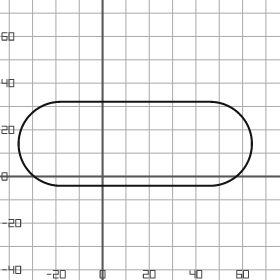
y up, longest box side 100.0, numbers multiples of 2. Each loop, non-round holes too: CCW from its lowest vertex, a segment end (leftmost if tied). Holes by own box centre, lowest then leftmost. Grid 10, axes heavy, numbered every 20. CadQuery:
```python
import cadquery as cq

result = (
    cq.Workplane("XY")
    .moveTo(-18.0, -4.0)
    .lineTo(46.0, -4.0)
    .threePointArc((64.0, 14.0), (46.0, 32.0))
    .lineTo(-18.0, 32.0)
    .threePointArc((-36.0, 14.0), (-18.0, -4.0))
    .close()
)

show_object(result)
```